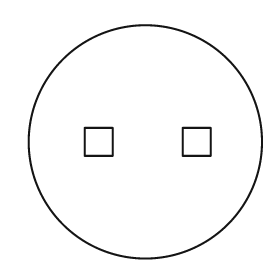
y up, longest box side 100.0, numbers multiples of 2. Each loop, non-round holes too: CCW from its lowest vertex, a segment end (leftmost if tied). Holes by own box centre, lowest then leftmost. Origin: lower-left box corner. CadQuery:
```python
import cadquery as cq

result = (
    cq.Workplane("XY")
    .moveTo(50.0, 50.0)
    .circle(50.0)
    .moveTo(24.0, 44.0)
    .lineTo(36.0, 44.0)
    .lineTo(36.0, 56.0)
    .lineTo(24.0, 56.0)
    .close()
    .moveTo(66.0, 44.0)
    .lineTo(78.0, 44.0)
    .lineTo(78.0, 56.0)
    .lineTo(66.0, 56.0)
    .close()
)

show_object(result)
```